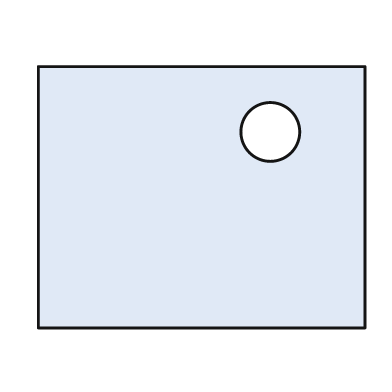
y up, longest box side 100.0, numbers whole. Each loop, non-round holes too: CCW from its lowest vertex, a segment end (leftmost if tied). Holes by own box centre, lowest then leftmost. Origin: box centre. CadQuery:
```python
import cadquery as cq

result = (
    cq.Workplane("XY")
    .moveTo(-50.0, -40.0)
    .lineTo(50.0, -40.0)
    .lineTo(50.0, 40.0)
    .lineTo(-50.0, 40.0)
    .close()
    .moveTo(21.0, 20.0)
    .circle(9.0)
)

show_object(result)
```